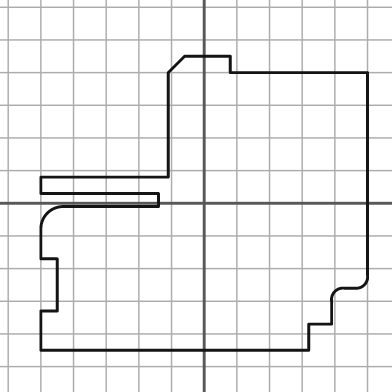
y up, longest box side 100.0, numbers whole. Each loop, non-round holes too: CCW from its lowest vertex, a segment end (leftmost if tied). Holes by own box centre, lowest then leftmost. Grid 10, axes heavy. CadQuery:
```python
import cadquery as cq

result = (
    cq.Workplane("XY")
    .moveTo(-50.0, -45.0)
    .lineTo(32.0, -45.0)
    .lineTo(32.0, -37.0)
    .lineTo(39.0, -37.0)
    .lineTo(39.0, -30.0)
    .threePointArc((40.0, -27.0), (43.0, -26.0))
    .lineTo(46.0, -26.0)
    .threePointArc((49.0, -25.0), (50.0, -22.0))
    .lineTo(50.0, 40.0)
    .lineTo(8.0, 40.0)
    .lineTo(8.0, 45.0)
    .lineTo(-6.0, 45.0)
    .lineTo(-11.0, 40.0)
    .lineTo(-11.0, 8.0)
    .lineTo(-50.0, 8.0)
    .lineTo(-50.0, 3.0)
    .lineTo(-14.0, 3.0)
    .lineTo(-14.0, -1.0)
    .lineTo(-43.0, -1.0)
    .threePointArc((-48.0, -3.0), (-50.0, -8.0))
    .lineTo(-50.0, -17.0)
    .lineTo(-45.0, -17.0)
    .lineTo(-45.0, -33.0)
    .lineTo(-50.0, -33.0)
    .close()
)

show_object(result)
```